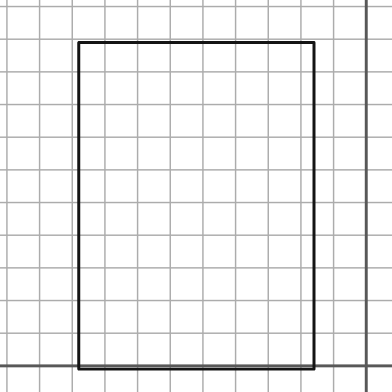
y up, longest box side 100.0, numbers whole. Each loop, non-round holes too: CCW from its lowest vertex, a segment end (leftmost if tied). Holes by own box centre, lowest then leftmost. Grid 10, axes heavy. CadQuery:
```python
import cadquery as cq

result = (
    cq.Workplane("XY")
    .moveTo(-88.0, -1.0)
    .lineTo(-16.0, -1.0)
    .lineTo(-16.0, 99.0)
    .lineTo(-88.0, 99.0)
    .close()
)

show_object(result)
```